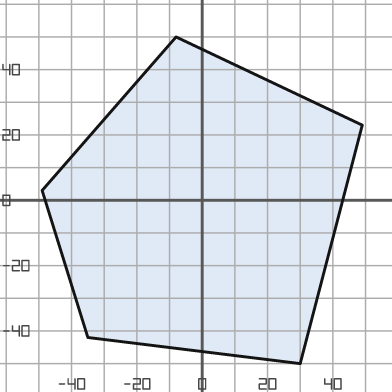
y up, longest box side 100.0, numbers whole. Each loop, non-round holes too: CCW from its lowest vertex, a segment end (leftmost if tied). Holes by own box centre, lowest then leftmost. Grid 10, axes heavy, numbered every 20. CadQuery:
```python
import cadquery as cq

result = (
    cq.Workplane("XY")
    .moveTo(30.0, -50.0)
    .lineTo(49.0, 23.0)
    .lineTo(-8.0, 50.0)
    .lineTo(-49.0, 3.0)
    .lineTo(-35.0, -42.0)
    .close()
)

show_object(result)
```